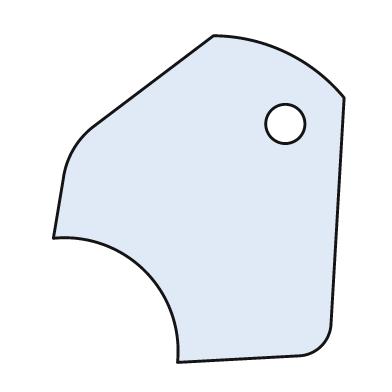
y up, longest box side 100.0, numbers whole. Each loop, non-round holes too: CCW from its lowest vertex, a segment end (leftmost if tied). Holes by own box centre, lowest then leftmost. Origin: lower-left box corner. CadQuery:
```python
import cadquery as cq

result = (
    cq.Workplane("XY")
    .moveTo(38.0, 0.0)
    .lineTo(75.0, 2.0)
    .threePointArc((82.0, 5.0), (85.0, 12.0))
    .lineTo(89.0, 81.0)
    .threePointArc((71.0, 95.0), (49.0, 100.0))
    .lineTo(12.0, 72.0)
    .threePointArc((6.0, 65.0), (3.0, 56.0))
    .lineTo(0.0, 38.0)
    .threePointArc((28.0, 28.0), (38.0, 0.0))
    .close()
    .moveTo(71.0, 73.0)
    .circle(6.0)
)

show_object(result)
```